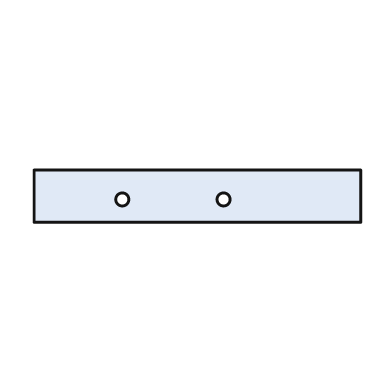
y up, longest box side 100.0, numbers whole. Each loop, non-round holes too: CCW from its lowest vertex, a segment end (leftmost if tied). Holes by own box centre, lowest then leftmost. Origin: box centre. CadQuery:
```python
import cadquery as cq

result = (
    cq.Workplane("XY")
    .moveTo(-50.0, -8.0)
    .lineTo(50.0, -8.0)
    .lineTo(50.0, 8.0)
    .lineTo(-50.0, 8.0)
    .close()
    .moveTo(-23.0, -1.0)
    .circle(2.0)
    .moveTo(8.0, -1.0)
    .circle(2.0)
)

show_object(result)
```